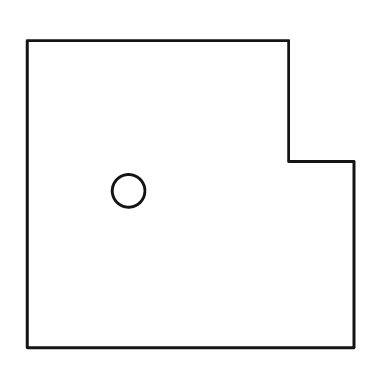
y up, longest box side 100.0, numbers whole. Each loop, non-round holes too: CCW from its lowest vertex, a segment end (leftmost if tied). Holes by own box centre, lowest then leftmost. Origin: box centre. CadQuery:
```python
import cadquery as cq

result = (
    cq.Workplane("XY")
    .moveTo(-50.0, -47.0)
    .lineTo(50.0, -47.0)
    .lineTo(50.0, 10.0)
    .lineTo(30.0, 10.0)
    .lineTo(30.0, 47.0)
    .lineTo(-50.0, 47.0)
    .close()
    .moveTo(-19.0, 1.0)
    .circle(5.0)
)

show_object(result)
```